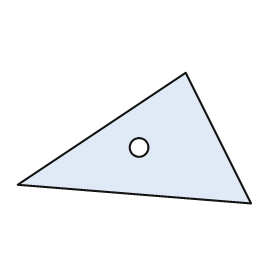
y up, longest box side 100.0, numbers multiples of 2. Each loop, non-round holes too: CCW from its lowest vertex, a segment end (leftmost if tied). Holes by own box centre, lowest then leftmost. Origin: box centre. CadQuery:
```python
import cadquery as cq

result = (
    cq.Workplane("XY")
    .moveTo(50.0, -28.0)
    .lineTo(22.0, 28.0)
    .lineTo(-50.0, -20.0)
    .close()
    .moveTo(2.0, -4.0)
    .circle(4.0)
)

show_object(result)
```